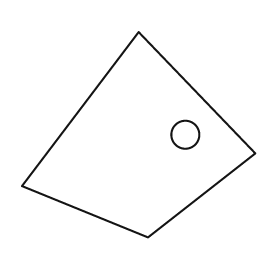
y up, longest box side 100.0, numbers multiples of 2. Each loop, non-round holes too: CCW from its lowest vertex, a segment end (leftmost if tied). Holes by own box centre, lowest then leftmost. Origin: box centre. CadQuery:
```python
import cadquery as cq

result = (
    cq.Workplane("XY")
    .moveTo(4.0, -44.0)
    .lineTo(50.0, -8.0)
    .lineTo(0.0, 44.0)
    .lineTo(-50.0, -22.0)
    .close()
    .moveTo(20.0, 0.0)
    .circle(6.0)
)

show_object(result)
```